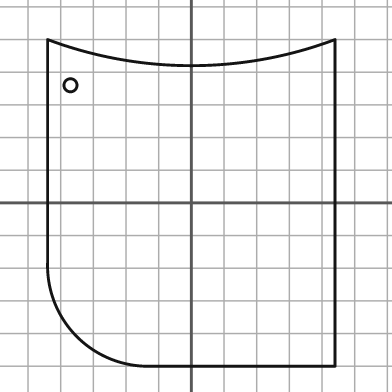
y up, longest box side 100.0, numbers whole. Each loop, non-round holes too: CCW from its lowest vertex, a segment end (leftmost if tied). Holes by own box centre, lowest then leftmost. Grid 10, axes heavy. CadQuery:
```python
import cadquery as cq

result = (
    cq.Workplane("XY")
    .moveTo(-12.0, -50.0)
    .lineTo(44.0, -50.0)
    .lineTo(44.0, 50.0)
    .threePointArc((0.0, 42.0), (-44.0, 50.0))
    .lineTo(-44.0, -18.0)
    .threePointArc((-35.0, -41.0), (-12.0, -50.0))
    .close()
    .moveTo(-37.0, 36.0)
    .circle(2.0)
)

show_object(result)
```